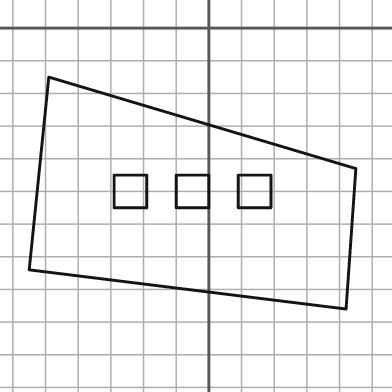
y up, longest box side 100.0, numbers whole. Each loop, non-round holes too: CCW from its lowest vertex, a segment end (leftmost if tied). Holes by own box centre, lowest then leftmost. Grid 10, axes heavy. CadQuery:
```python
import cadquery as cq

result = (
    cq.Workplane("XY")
    .moveTo(42.0, -86.0)
    .lineTo(45.0, -43.0)
    .lineTo(-49.0, -15.0)
    .lineTo(-55.0, -74.0)
    .close()
    .moveTo(-29.0, -55.0)
    .lineTo(-19.0, -55.0)
    .lineTo(-19.0, -45.0)
    .lineTo(-29.0, -45.0)
    .close()
    .moveTo(-10.0, -55.0)
    .lineTo(0.0, -55.0)
    .lineTo(0.0, -45.0)
    .lineTo(-10.0, -45.0)
    .close()
    .moveTo(9.0, -55.0)
    .lineTo(19.0, -55.0)
    .lineTo(19.0, -45.0)
    .lineTo(9.0, -45.0)
    .close()
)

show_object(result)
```